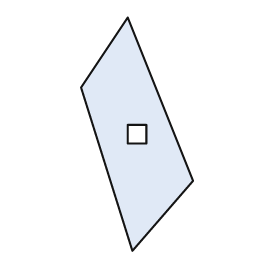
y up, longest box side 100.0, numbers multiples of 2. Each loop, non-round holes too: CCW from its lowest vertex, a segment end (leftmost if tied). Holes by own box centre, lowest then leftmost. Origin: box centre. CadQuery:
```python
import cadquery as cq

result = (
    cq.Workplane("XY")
    .moveTo(-2.0, -50.0)
    .lineTo(24.0, -20.0)
    .lineTo(-4.0, 50.0)
    .lineTo(-24.0, 20.0)
    .close()
    .moveTo(-4.0, -4.0)
    .lineTo(4.0, -4.0)
    .lineTo(4.0, 4.0)
    .lineTo(-4.0, 4.0)
    .close()
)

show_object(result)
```